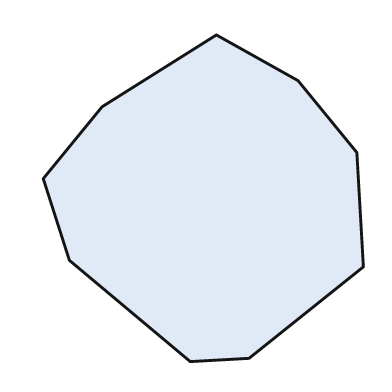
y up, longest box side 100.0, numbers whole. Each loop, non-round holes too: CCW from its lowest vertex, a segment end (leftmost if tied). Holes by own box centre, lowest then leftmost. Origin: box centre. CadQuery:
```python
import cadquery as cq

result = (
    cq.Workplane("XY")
    .moveTo(-4.0, -50.0)
    .lineTo(14.0, -49.0)
    .lineTo(49.0, -21.0)
    .lineTo(47.0, 14.0)
    .lineTo(29.0, 36.0)
    .lineTo(4.0, 50.0)
    .lineTo(-31.0, 28.0)
    .lineTo(-49.0, 6.0)
    .lineTo(-41.0, -19.0)
    .close()
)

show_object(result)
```